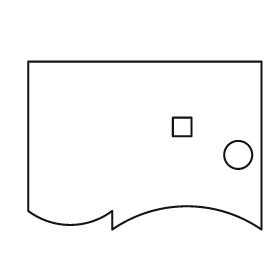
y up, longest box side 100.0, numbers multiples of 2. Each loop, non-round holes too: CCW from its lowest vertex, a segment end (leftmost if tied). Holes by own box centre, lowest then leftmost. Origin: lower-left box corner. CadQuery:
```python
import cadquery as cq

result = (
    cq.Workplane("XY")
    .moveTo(36.0, 0.0)
    .threePointArc((68.0, 10.0), (100.0, 0.0))
    .lineTo(100.0, 72.0)
    .lineTo(0.0, 72.0)
    .lineTo(0.0, 8.0)
    .threePointArc((18.0, 2.0), (36.0, 8.0))
    .close()
    .moveTo(90.0, 32.0)
    .circle(6.0)
    .moveTo(62.0, 40.0)
    .lineTo(70.0, 40.0)
    .lineTo(70.0, 48.0)
    .lineTo(62.0, 48.0)
    .close()
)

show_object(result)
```